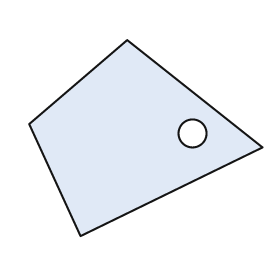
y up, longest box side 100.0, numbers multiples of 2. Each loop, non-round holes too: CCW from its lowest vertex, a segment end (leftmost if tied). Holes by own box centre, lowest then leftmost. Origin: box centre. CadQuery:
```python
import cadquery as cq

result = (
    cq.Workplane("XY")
    .moveTo(-28.0, -42.0)
    .lineTo(50.0, -4.0)
    .lineTo(-8.0, 42.0)
    .lineTo(-50.0, 6.0)
    .close()
    .moveTo(20.0, 2.0)
    .circle(6.0)
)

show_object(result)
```